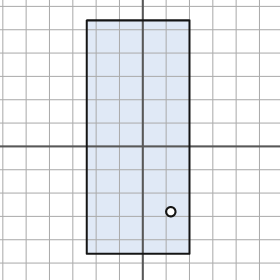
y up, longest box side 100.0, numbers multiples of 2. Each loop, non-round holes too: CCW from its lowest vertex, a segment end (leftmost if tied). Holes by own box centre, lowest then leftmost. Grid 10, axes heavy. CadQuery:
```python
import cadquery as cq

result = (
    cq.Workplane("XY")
    .moveTo(-24.0, -46.0)
    .lineTo(20.0, -46.0)
    .lineTo(20.0, 54.0)
    .lineTo(-24.0, 54.0)
    .close()
    .moveTo(12.0, -28.0)
    .circle(2.0)
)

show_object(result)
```